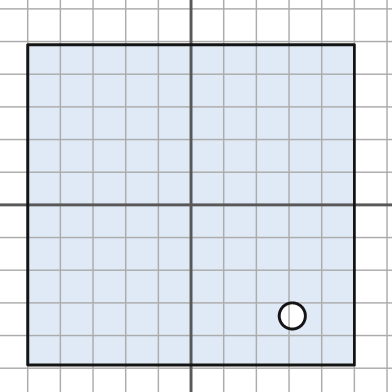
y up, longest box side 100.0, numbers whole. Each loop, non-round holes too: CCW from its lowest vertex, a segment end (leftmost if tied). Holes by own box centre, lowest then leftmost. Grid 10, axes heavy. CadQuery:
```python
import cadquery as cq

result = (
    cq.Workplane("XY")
    .moveTo(-50.0, -49.0)
    .lineTo(50.0, -49.0)
    .lineTo(50.0, 49.0)
    .lineTo(-50.0, 49.0)
    .close()
    .moveTo(31.0, -34.0)
    .circle(4.0)
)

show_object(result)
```